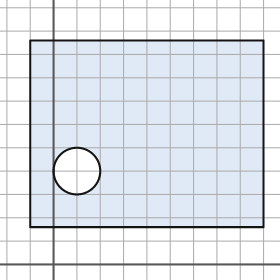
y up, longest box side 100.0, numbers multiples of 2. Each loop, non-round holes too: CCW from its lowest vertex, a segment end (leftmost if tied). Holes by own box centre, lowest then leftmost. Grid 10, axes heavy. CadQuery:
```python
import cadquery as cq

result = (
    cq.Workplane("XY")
    .moveTo(-10.0, 16.0)
    .lineTo(90.0, 16.0)
    .lineTo(90.0, 96.0)
    .lineTo(-10.0, 96.0)
    .close()
    .moveTo(10.0, 40.0)
    .circle(10.0)
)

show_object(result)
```